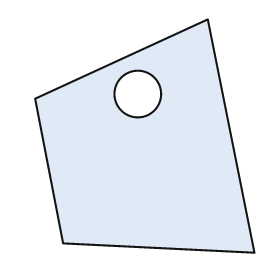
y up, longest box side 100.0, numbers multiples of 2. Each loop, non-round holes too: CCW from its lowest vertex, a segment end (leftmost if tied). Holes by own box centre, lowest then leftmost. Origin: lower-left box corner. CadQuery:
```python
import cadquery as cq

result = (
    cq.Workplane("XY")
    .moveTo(94.0, 0.0)
    .lineTo(74.0, 100.0)
    .lineTo(0.0, 66.0)
    .lineTo(12.0, 4.0)
    .close()
    .moveTo(44.0, 68.0)
    .circle(10.0)
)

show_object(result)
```